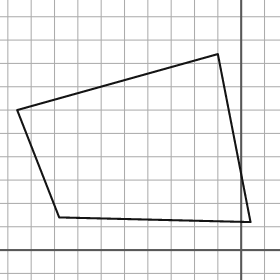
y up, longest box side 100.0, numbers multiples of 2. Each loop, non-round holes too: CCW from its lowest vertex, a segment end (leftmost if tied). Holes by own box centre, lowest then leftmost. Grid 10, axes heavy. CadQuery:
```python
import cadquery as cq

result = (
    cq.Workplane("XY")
    .moveTo(4.0, 12.0)
    .lineTo(-10.0, 84.0)
    .lineTo(-96.0, 60.0)
    .lineTo(-78.0, 14.0)
    .close()
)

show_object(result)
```